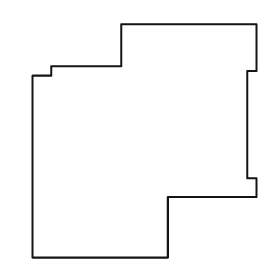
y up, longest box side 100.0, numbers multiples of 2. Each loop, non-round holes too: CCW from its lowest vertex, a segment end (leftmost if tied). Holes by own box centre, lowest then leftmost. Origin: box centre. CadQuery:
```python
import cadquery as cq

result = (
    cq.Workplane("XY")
    .moveTo(-48.0, -50.0)
    .lineTo(10.0, -50.0)
    .lineTo(10.0, -24.0)
    .lineTo(48.0, -24.0)
    .lineTo(48.0, -16.0)
    .lineTo(44.0, -16.0)
    .lineTo(44.0, 30.0)
    .lineTo(48.0, 30.0)
    .lineTo(48.0, 50.0)
    .lineTo(-10.0, 50.0)
    .lineTo(-10.0, 32.0)
    .lineTo(-40.0, 32.0)
    .lineTo(-40.0, 28.0)
    .lineTo(-48.0, 28.0)
    .close()
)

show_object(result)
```